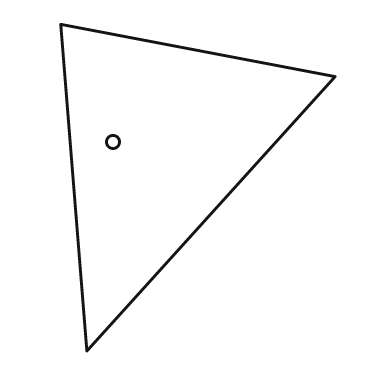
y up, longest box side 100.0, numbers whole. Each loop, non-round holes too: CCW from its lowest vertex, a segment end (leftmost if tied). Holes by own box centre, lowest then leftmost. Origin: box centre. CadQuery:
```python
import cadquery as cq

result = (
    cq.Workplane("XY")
    .moveTo(-34.0, -50.0)
    .lineTo(42.0, 34.0)
    .lineTo(-42.0, 50.0)
    .close()
    .moveTo(-26.0, 14.0)
    .circle(2.0)
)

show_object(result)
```